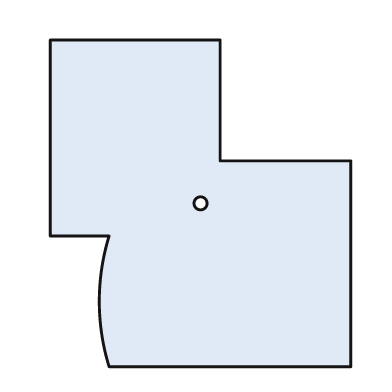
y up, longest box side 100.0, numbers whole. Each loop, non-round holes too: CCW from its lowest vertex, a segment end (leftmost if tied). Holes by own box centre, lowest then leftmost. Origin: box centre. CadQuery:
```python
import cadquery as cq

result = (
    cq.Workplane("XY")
    .moveTo(-28.0, -50.0)
    .lineTo(46.0, -50.0)
    .lineTo(46.0, 13.0)
    .lineTo(6.0, 13.0)
    .lineTo(6.0, 50.0)
    .lineTo(-46.0, 50.0)
    .lineTo(-46.0, -10.0)
    .lineTo(-28.0, -10.0)
    .threePointArc((-31.0, -30.0), (-28.0, -50.0))
    .close()
    .moveTo(0.0, 0.0)
    .circle(2.0)
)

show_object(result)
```